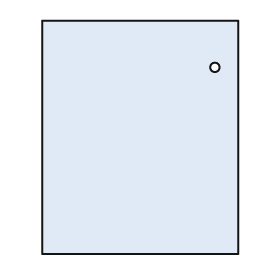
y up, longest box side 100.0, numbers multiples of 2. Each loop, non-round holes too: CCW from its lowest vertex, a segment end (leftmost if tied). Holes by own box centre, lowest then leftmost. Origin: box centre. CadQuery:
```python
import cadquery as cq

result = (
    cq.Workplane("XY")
    .moveTo(-42.0, -50.0)
    .lineTo(42.0, -50.0)
    .lineTo(42.0, 50.0)
    .lineTo(-42.0, 50.0)
    .close()
    .moveTo(32.0, 30.0)
    .circle(2.0)
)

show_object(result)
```